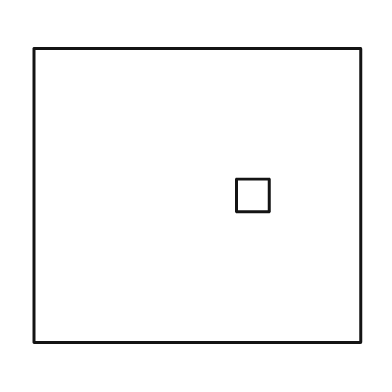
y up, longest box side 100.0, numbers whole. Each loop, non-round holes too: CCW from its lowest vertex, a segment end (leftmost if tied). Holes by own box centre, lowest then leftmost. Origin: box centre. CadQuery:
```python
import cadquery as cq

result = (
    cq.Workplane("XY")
    .moveTo(-50.0, -45.0)
    .lineTo(50.0, -45.0)
    .lineTo(50.0, 45.0)
    .lineTo(-50.0, 45.0)
    .close()
    .moveTo(12.0, -5.0)
    .lineTo(22.0, -5.0)
    .lineTo(22.0, 5.0)
    .lineTo(12.0, 5.0)
    .close()
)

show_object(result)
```